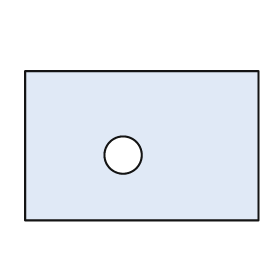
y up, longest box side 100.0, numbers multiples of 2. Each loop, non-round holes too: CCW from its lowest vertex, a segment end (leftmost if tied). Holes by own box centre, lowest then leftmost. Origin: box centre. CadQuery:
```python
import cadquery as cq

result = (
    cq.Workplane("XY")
    .moveTo(-50.0, -32.0)
    .lineTo(50.0, -32.0)
    .lineTo(50.0, 32.0)
    .lineTo(-50.0, 32.0)
    .close()
    .moveTo(-8.0, -4.0)
    .circle(8.0)
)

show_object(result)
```